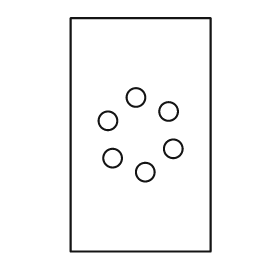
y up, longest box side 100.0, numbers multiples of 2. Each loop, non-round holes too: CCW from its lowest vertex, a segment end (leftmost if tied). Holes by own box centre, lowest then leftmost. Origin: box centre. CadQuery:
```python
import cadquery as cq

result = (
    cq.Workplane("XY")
    .moveTo(-30.0, -50.0)
    .lineTo(30.0, -50.0)
    .lineTo(30.0, 50.0)
    .lineTo(-30.0, 50.0)
    .close()
    .moveTo(2.0, -16.0)
    .circle(4.0)
    .moveTo(-12.0, -10.0)
    .circle(4.0)
    .moveTo(14.0, -6.0)
    .circle(4.0)
    .moveTo(-14.0, 6.0)
    .circle(4.0)
    .moveTo(12.0, 10.0)
    .circle(4.0)
    .moveTo(-2.0, 16.0)
    .circle(4.0)
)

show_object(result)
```